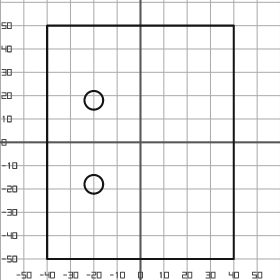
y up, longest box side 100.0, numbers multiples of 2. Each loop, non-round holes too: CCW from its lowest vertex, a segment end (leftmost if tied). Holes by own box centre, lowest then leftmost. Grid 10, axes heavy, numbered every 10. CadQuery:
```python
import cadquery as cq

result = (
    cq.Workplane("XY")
    .moveTo(-40.0, -50.0)
    .lineTo(40.0, -50.0)
    .lineTo(40.0, 50.0)
    .lineTo(-40.0, 50.0)
    .close()
    .moveTo(-20.0, -18.0)
    .circle(4.0)
    .moveTo(-20.0, 18.0)
    .circle(4.0)
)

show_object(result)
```